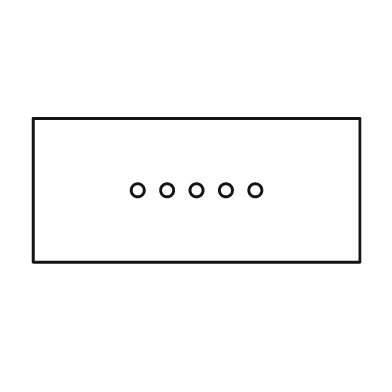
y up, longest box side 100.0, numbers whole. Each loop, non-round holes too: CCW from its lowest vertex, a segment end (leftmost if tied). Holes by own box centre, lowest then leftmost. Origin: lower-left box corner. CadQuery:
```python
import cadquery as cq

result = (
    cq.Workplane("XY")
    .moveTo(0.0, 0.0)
    .lineTo(100.0, 0.0)
    .lineTo(100.0, 44.0)
    .lineTo(0.0, 44.0)
    .close()
    .moveTo(32.0, 22.0)
    .circle(2.0)
    .moveTo(41.0, 22.0)
    .circle(2.0)
    .moveTo(50.0, 22.0)
    .circle(2.0)
    .moveTo(59.0, 22.0)
    .circle(2.0)
    .moveTo(68.0, 22.0)
    .circle(2.0)
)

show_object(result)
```